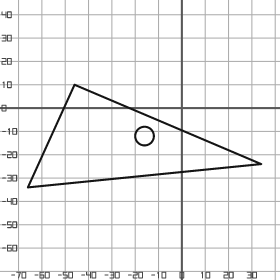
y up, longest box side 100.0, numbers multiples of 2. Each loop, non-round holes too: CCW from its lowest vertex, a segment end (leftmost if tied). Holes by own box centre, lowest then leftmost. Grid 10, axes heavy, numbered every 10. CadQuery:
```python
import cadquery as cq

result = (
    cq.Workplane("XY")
    .moveTo(-66.0, -34.0)
    .lineTo(34.0, -24.0)
    .lineTo(-46.0, 10.0)
    .close()
    .moveTo(-16.0, -12.0)
    .circle(4.0)
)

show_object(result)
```